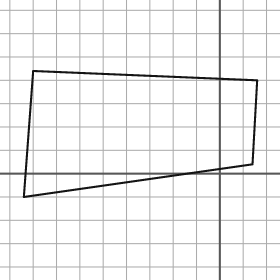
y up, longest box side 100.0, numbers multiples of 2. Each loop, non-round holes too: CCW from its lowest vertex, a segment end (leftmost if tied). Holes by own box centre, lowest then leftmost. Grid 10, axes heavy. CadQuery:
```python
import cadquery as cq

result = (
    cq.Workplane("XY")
    .moveTo(-84.0, -10.0)
    .lineTo(14.0, 4.0)
    .lineTo(16.0, 40.0)
    .lineTo(-80.0, 44.0)
    .close()
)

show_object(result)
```